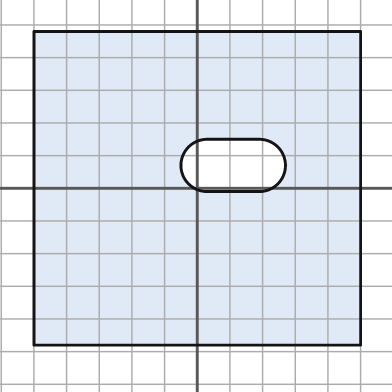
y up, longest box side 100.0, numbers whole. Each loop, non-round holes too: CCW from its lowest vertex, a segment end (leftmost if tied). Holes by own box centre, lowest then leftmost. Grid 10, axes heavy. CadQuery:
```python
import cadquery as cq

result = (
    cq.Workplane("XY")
    .moveTo(-50.0, -48.0)
    .lineTo(50.0, -48.0)
    .lineTo(50.0, 48.0)
    .lineTo(-50.0, 48.0)
    .close()
    .moveTo(3.0, -1.0)
    .lineTo(19.0, -1.0)
    .threePointArc((27.0, 7.0), (19.0, 15.0))
    .lineTo(3.0, 15.0)
    .threePointArc((-5.0, 7.0), (3.0, -1.0))
    .close()
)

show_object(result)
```